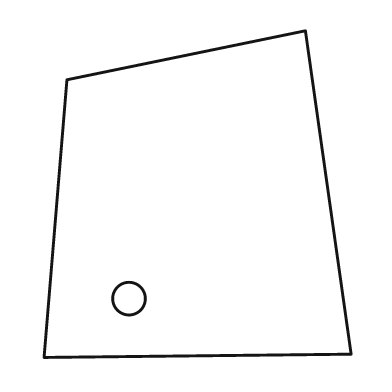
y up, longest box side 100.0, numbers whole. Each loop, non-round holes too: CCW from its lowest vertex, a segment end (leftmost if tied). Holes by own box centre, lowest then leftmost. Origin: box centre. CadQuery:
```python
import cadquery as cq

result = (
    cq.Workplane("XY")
    .moveTo(-47.0, -50.0)
    .lineTo(47.0, -49.0)
    .lineTo(33.0, 50.0)
    .lineTo(-40.0, 35.0)
    .close()
    .moveTo(-21.0, -32.0)
    .circle(5.0)
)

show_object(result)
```